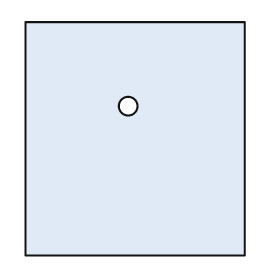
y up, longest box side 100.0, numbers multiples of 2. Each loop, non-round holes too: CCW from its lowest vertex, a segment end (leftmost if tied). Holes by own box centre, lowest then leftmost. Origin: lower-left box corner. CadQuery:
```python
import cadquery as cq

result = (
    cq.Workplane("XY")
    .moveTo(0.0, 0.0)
    .lineTo(94.0, 0.0)
    .lineTo(94.0, 100.0)
    .lineTo(0.0, 100.0)
    .close()
    .moveTo(44.0, 64.0)
    .circle(4.0)
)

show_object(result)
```